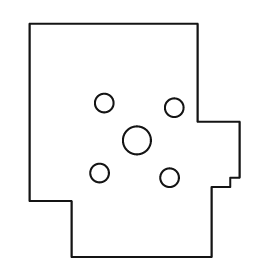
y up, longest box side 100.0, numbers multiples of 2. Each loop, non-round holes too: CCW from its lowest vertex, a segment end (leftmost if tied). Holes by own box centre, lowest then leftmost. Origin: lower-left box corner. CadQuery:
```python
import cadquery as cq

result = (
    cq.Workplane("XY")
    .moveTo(18.0, 0.0)
    .lineTo(78.0, 0.0)
    .lineTo(78.0, 30.0)
    .lineTo(86.0, 30.0)
    .lineTo(86.0, 34.0)
    .lineTo(90.0, 34.0)
    .lineTo(90.0, 58.0)
    .lineTo(72.0, 58.0)
    .lineTo(72.0, 100.0)
    .lineTo(0.0, 100.0)
    .lineTo(0.0, 24.0)
    .lineTo(18.0, 24.0)
    .close()
    .moveTo(60.0, 34.0)
    .circle(4.0)
    .moveTo(30.0, 36.0)
    .circle(4.0)
    .moveTo(46.0, 50.0)
    .circle(6.0)
    .moveTo(62.0, 64.0)
    .circle(4.0)
    .moveTo(32.0, 66.0)
    .circle(4.0)
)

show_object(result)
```